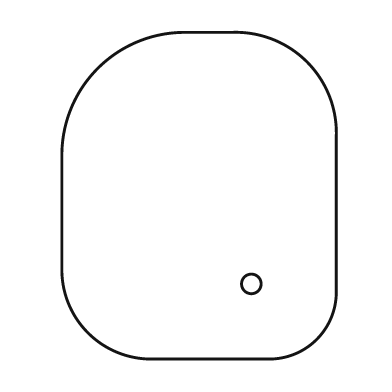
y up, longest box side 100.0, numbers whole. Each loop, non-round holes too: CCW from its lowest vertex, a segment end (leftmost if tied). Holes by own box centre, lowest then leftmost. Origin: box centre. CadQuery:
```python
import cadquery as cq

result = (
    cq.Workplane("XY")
    .moveTo(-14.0, -50.0)
    .lineTo(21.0, -50.0)
    .threePointArc((36.0, -44.0), (42.0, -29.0))
    .lineTo(42.0, 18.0)
    .threePointArc((33.0, 41.0), (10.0, 50.0))
    .lineTo(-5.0, 50.0)
    .threePointArc((-31.0, 39.0), (-42.0, 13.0))
    .lineTo(-42.0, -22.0)
    .threePointArc((-34.0, -42.0), (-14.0, -50.0))
    .close()
    .moveTo(16.0, -27.0)
    .circle(3.0)
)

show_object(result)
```